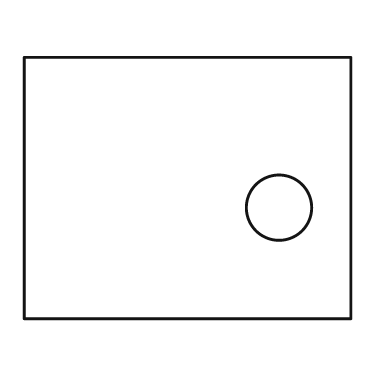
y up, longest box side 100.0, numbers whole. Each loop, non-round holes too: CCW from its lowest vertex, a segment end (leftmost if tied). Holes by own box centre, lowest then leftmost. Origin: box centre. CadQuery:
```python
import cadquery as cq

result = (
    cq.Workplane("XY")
    .moveTo(-50.0, -40.0)
    .lineTo(50.0, -40.0)
    .lineTo(50.0, 40.0)
    .lineTo(-50.0, 40.0)
    .close()
    .moveTo(28.0, -6.0)
    .circle(10.0)
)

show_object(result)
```